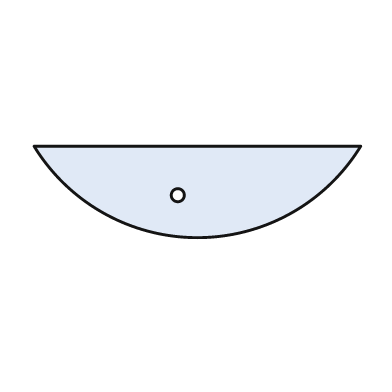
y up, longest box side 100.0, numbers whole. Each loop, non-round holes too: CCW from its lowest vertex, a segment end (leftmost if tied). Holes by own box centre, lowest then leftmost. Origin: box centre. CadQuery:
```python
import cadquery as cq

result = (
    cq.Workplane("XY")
    .moveTo(-50.0, 14.0)
    .threePointArc((0.0, -14.0), (50.0, 14.0))
    .close()
    .moveTo(-6.0, -1.0)
    .circle(2.0)
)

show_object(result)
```